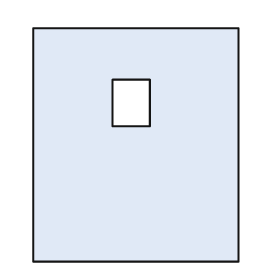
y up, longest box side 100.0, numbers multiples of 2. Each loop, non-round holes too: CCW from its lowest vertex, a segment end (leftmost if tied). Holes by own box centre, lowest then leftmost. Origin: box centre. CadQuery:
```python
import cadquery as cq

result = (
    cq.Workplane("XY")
    .moveTo(-44.0, -50.0)
    .lineTo(44.0, -50.0)
    .lineTo(44.0, 50.0)
    .lineTo(-44.0, 50.0)
    .close()
    .moveTo(-10.0, 8.0)
    .lineTo(6.0, 8.0)
    .lineTo(6.0, 28.0)
    .lineTo(-10.0, 28.0)
    .close()
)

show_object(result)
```